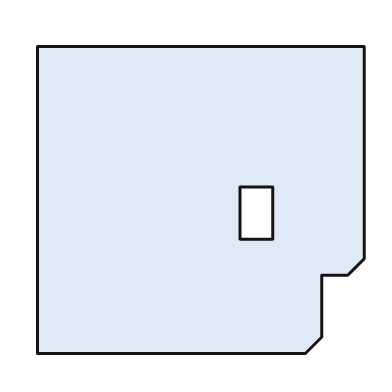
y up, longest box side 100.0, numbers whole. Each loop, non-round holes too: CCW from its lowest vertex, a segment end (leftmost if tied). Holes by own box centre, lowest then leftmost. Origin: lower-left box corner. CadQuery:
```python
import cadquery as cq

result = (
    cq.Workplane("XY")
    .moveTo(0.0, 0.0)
    .lineTo(82.0, 0.0)
    .lineTo(87.0, 5.0)
    .lineTo(87.0, 24.0)
    .lineTo(95.0, 24.0)
    .lineTo(100.0, 29.0)
    .lineTo(100.0, 94.0)
    .lineTo(0.0, 94.0)
    .close()
    .moveTo(62.0, 35.0)
    .lineTo(72.0, 35.0)
    .lineTo(72.0, 51.0)
    .lineTo(62.0, 51.0)
    .close()
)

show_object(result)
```